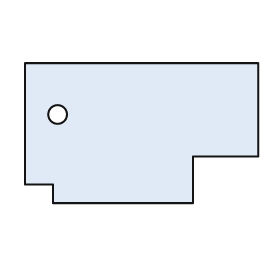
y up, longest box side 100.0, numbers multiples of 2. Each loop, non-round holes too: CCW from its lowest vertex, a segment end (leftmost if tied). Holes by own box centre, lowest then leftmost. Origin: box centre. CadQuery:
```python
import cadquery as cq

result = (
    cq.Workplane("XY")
    .moveTo(-38.0, -30.0)
    .lineTo(22.0, -30.0)
    .lineTo(22.0, -10.0)
    .lineTo(50.0, -10.0)
    .lineTo(50.0, 30.0)
    .lineTo(-50.0, 30.0)
    .lineTo(-50.0, -22.0)
    .lineTo(-38.0, -22.0)
    .close()
    .moveTo(-36.0, 8.0)
    .circle(4.0)
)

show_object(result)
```